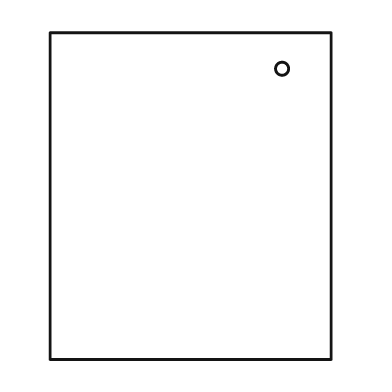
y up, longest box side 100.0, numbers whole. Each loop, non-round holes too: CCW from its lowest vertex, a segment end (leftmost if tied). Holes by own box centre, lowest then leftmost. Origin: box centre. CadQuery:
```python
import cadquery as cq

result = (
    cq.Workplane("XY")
    .moveTo(-43.0, -50.0)
    .lineTo(43.0, -50.0)
    .lineTo(43.0, 50.0)
    .lineTo(-43.0, 50.0)
    .close()
    .moveTo(28.0, 39.0)
    .circle(2.0)
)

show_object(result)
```